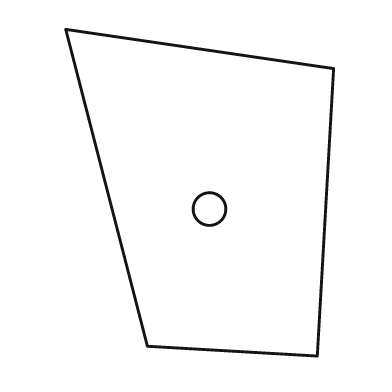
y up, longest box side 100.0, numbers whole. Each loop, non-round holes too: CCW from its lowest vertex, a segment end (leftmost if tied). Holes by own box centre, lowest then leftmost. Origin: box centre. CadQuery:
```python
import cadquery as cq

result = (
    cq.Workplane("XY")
    .moveTo(36.0, -50.0)
    .lineTo(41.0, 38.0)
    .lineTo(-41.0, 50.0)
    .lineTo(-16.0, -47.0)
    .close()
    .moveTo(3.0, -5.0)
    .circle(5.0)
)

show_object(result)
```